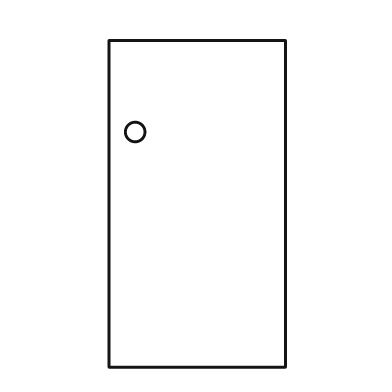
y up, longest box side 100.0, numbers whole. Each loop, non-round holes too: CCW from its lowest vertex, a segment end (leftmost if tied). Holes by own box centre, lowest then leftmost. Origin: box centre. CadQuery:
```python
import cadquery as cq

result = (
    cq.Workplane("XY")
    .moveTo(-27.0, -50.0)
    .lineTo(27.0, -50.0)
    .lineTo(27.0, 50.0)
    .lineTo(-27.0, 50.0)
    .close()
    .moveTo(-19.0, 22.0)
    .circle(3.0)
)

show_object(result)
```